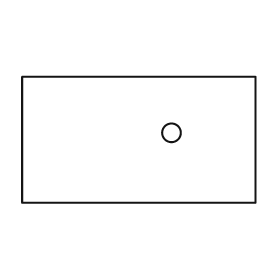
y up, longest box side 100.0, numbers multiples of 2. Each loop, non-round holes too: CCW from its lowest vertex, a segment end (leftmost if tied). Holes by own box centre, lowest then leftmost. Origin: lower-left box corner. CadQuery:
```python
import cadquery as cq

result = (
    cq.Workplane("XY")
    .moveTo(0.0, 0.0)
    .lineTo(100.0, 0.0)
    .lineTo(100.0, 54.0)
    .lineTo(0.0, 54.0)
    .close()
    .moveTo(64.0, 30.0)
    .circle(4.0)
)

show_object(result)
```